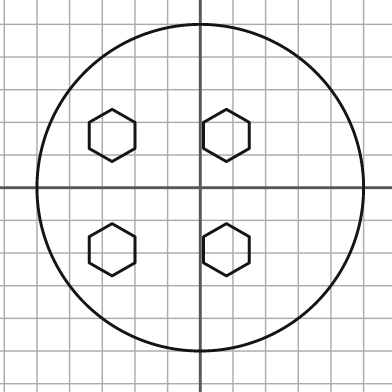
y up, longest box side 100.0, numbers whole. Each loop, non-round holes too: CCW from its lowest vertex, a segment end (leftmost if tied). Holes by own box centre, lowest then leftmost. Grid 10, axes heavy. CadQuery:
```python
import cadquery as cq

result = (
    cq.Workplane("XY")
    .moveTo(0.0, 0.0)
    .circle(50.0)
    .moveTo(-27.0, -27.0)
    .lineTo(-20.0, -23.0)
    .lineTo(-20.0, -15.0)
    .lineTo(-27.0, -11.0)
    .lineTo(-34.0, -15.0)
    .lineTo(-34.0, -23.0)
    .close()
    .moveTo(8.0, -27.0)
    .lineTo(15.0, -23.0)
    .lineTo(15.0, -15.0)
    .lineTo(8.0, -11.0)
    .lineTo(1.0, -15.0)
    .lineTo(1.0, -23.0)
    .close()
    .moveTo(-27.0, 8.0)
    .lineTo(-20.0, 12.0)
    .lineTo(-20.0, 20.0)
    .lineTo(-27.0, 24.0)
    .lineTo(-34.0, 20.0)
    .lineTo(-34.0, 12.0)
    .close()
    .moveTo(8.0, 8.0)
    .lineTo(15.0, 12.0)
    .lineTo(15.0, 20.0)
    .lineTo(8.0, 24.0)
    .lineTo(1.0, 20.0)
    .lineTo(1.0, 12.0)
    .close()
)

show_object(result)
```